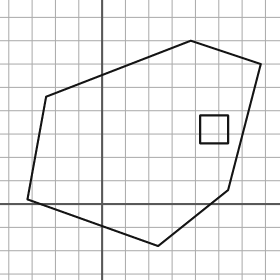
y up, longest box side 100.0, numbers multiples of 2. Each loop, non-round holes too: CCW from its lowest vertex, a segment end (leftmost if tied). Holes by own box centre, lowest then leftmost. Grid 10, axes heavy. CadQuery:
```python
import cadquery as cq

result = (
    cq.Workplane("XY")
    .moveTo(24.0, -18.0)
    .lineTo(54.0, 6.0)
    .lineTo(68.0, 60.0)
    .lineTo(38.0, 70.0)
    .lineTo(-24.0, 46.0)
    .lineTo(-32.0, 2.0)
    .close()
    .moveTo(42.0, 26.0)
    .lineTo(54.0, 26.0)
    .lineTo(54.0, 38.0)
    .lineTo(42.0, 38.0)
    .close()
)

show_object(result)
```